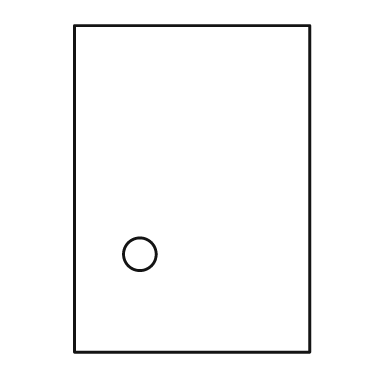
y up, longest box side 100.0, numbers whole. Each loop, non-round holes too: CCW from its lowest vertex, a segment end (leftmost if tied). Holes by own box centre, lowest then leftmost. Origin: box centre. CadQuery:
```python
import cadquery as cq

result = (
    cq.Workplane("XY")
    .moveTo(-36.0, -50.0)
    .lineTo(36.0, -50.0)
    .lineTo(36.0, 50.0)
    .lineTo(-36.0, 50.0)
    .close()
    .moveTo(-16.0, -20.0)
    .circle(5.0)
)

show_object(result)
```